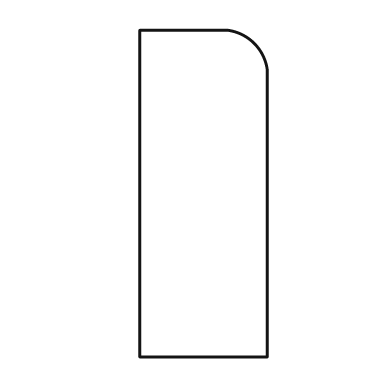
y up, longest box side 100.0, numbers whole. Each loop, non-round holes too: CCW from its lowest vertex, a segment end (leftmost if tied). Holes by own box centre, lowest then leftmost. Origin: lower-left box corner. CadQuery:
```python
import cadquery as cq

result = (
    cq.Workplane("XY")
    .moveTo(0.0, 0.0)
    .lineTo(39.0, 0.0)
    .lineTo(39.0, 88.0)
    .threePointArc((35.0, 96.0), (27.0, 100.0))
    .lineTo(0.0, 100.0)
    .close()
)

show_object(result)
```